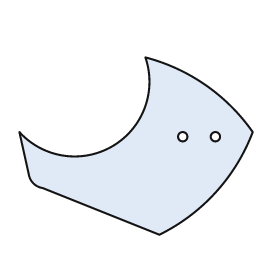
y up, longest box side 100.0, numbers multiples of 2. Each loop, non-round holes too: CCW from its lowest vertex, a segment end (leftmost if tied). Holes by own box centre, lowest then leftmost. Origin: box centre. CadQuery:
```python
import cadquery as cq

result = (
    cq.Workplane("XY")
    .moveTo(10.0, -38.0)
    .threePointArc((34.0, -20.0), (50.0, 6.0))
    .threePointArc((30.0, 26.0), (4.0, 38.0))
    .threePointArc((-10.0, 0.0), (-50.0, 6.0))
    .lineTo(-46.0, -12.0)
    .threePointArc((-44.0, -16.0), (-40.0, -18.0))
    .close()
    .moveTo(20.0, 4.0)
    .circle(2.0)
    .moveTo(34.0, 4.0)
    .circle(2.0)
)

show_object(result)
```